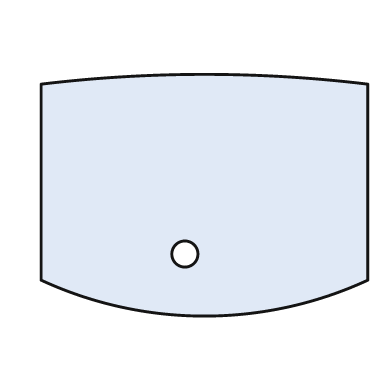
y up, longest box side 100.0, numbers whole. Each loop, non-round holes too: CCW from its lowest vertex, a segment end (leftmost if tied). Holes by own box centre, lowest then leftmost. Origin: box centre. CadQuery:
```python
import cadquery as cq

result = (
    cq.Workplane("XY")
    .moveTo(-50.0, -26.0)
    .threePointArc((0.0, -37.0), (50.0, -26.0))
    .lineTo(50.0, 34.0)
    .threePointArc((0.0, 37.0), (-50.0, 34.0))
    .close()
    .moveTo(-6.0, -18.0)
    .circle(4.0)
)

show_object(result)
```